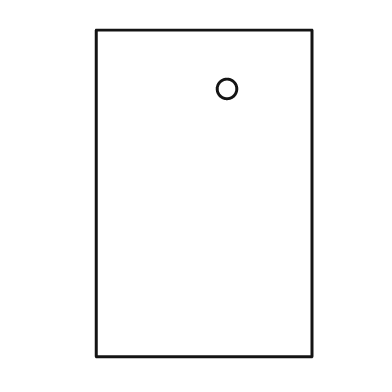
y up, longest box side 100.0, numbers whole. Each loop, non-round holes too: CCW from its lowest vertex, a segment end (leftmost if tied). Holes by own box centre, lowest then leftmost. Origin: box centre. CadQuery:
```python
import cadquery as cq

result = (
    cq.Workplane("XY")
    .moveTo(-33.0, -50.0)
    .lineTo(33.0, -50.0)
    .lineTo(33.0, 50.0)
    .lineTo(-33.0, 50.0)
    .close()
    .moveTo(7.0, 32.0)
    .circle(3.0)
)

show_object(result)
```